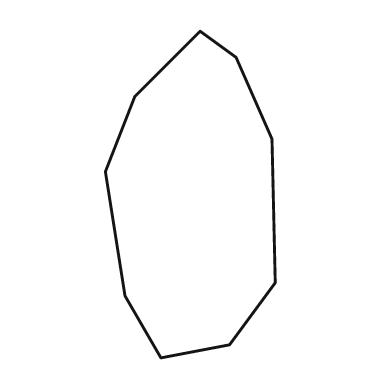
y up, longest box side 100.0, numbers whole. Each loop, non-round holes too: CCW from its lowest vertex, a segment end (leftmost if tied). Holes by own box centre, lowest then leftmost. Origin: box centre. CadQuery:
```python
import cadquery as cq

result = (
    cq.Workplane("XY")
    .moveTo(-9.0, -50.0)
    .lineTo(12.0, -46.0)
    .lineTo(26.0, -27.0)
    .lineTo(25.0, 17.0)
    .lineTo(14.0, 42.0)
    .lineTo(3.0, 50.0)
    .lineTo(-17.0, 30.0)
    .lineTo(-26.0, 7.0)
    .lineTo(-20.0, -31.0)
    .close()
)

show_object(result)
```